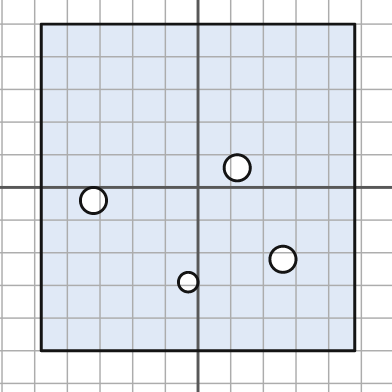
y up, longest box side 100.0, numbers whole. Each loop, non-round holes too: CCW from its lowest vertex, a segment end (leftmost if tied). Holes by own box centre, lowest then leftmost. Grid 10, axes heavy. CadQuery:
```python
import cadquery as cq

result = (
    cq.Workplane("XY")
    .moveTo(-48.0, -50.0)
    .lineTo(48.0, -50.0)
    .lineTo(48.0, 50.0)
    .lineTo(-48.0, 50.0)
    .close()
    .moveTo(-3.0, -29.0)
    .circle(3.0)
    .moveTo(26.0, -22.0)
    .circle(4.0)
    .moveTo(-32.0, -4.0)
    .circle(4.0)
    .moveTo(12.0, 6.0)
    .circle(4.0)
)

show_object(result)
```